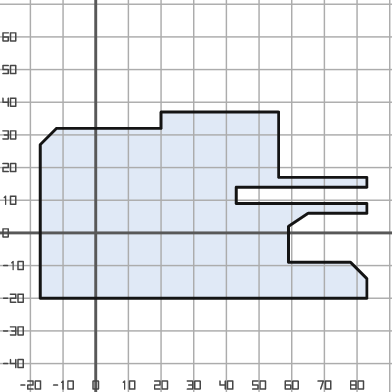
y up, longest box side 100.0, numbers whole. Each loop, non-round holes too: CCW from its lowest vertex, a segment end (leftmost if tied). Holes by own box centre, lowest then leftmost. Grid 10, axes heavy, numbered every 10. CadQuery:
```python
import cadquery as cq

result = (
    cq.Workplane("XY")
    .moveTo(-17.0, -20.0)
    .lineTo(83.0, -20.0)
    .lineTo(83.0, -14.0)
    .lineTo(78.0, -9.0)
    .lineTo(59.0, -9.0)
    .lineTo(59.0, 2.0)
    .lineTo(65.0, 6.0)
    .lineTo(83.0, 6.0)
    .lineTo(83.0, 9.0)
    .lineTo(43.0, 9.0)
    .lineTo(43.0, 14.0)
    .lineTo(83.0, 14.0)
    .lineTo(83.0, 17.0)
    .lineTo(56.0, 17.0)
    .lineTo(56.0, 37.0)
    .lineTo(20.0, 37.0)
    .lineTo(20.0, 32.0)
    .lineTo(-12.0, 32.0)
    .lineTo(-17.0, 27.0)
    .close()
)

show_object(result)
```